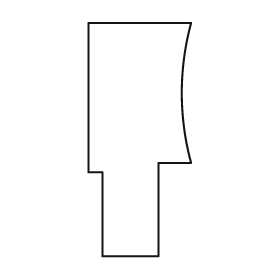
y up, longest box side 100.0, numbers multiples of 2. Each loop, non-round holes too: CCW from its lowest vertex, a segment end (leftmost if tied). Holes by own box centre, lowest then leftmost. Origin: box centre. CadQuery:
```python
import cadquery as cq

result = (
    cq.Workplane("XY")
    .moveTo(-16.0, -50.0)
    .lineTo(8.0, -50.0)
    .lineTo(8.0, -10.0)
    .lineTo(22.0, -10.0)
    .threePointArc((18.0, 20.0), (22.0, 50.0))
    .lineTo(-22.0, 50.0)
    .lineTo(-22.0, -14.0)
    .lineTo(-16.0, -14.0)
    .close()
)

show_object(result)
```